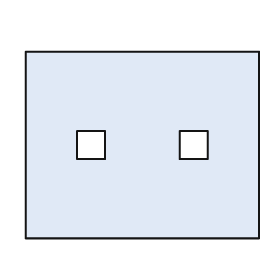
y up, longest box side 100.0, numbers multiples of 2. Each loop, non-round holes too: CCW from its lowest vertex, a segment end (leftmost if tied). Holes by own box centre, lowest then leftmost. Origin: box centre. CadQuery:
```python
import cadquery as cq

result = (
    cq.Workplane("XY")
    .moveTo(-50.0, -40.0)
    .lineTo(50.0, -40.0)
    .lineTo(50.0, 40.0)
    .lineTo(-50.0, 40.0)
    .close()
    .moveTo(-28.0, -6.0)
    .lineTo(-16.0, -6.0)
    .lineTo(-16.0, 6.0)
    .lineTo(-28.0, 6.0)
    .close()
    .moveTo(16.0, -6.0)
    .lineTo(28.0, -6.0)
    .lineTo(28.0, 6.0)
    .lineTo(16.0, 6.0)
    .close()
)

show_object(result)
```